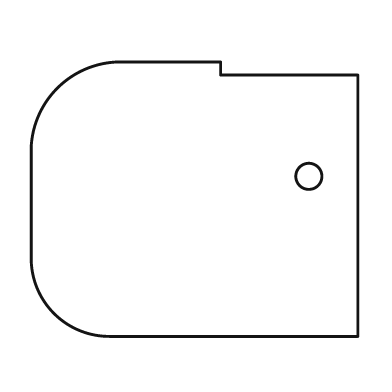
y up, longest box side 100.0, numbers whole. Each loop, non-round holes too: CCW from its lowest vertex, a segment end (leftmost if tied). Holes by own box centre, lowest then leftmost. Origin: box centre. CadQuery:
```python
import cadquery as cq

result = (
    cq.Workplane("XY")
    .moveTo(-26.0, -42.0)
    .lineTo(50.0, -42.0)
    .lineTo(50.0, 38.0)
    .lineTo(8.0, 38.0)
    .lineTo(8.0, 42.0)
    .lineTo(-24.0, 42.0)
    .threePointArc((-42.0, 34.0), (-50.0, 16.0))
    .lineTo(-50.0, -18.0)
    .threePointArc((-43.0, -35.0), (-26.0, -42.0))
    .close()
    .moveTo(35.0, 7.0)
    .circle(4.0)
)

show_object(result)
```